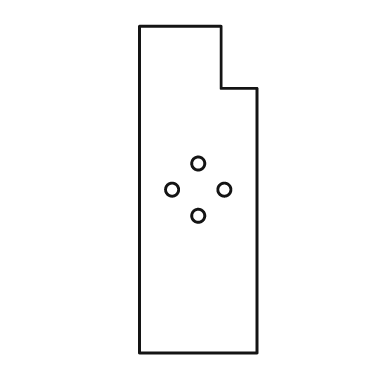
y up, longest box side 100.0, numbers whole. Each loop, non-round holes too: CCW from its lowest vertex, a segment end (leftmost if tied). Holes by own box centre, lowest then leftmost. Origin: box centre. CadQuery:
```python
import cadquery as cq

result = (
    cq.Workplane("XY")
    .moveTo(-18.0, -50.0)
    .lineTo(18.0, -50.0)
    .lineTo(18.0, 31.0)
    .lineTo(7.0, 31.0)
    .lineTo(7.0, 50.0)
    .lineTo(-18.0, 50.0)
    .close()
    .moveTo(0.0, -8.0)
    .circle(2.0)
    .moveTo(-8.0, 0.0)
    .circle(2.0)
    .moveTo(8.0, 0.0)
    .circle(2.0)
    .moveTo(0.0, 8.0)
    .circle(2.0)
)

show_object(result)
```